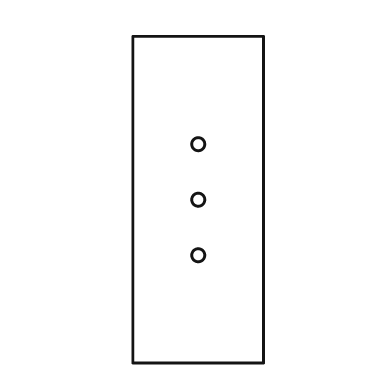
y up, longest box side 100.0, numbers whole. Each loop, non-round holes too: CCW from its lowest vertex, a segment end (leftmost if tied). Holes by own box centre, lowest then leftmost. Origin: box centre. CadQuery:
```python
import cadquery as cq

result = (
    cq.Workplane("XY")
    .moveTo(-20.0, -50.0)
    .lineTo(20.0, -50.0)
    .lineTo(20.0, 50.0)
    .lineTo(-20.0, 50.0)
    .close()
    .moveTo(0.0, -17.0)
    .circle(2.0)
    .moveTo(0.0, 0.0)
    .circle(2.0)
    .moveTo(0.0, 17.0)
    .circle(2.0)
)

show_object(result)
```